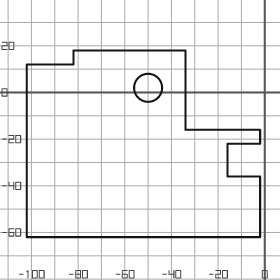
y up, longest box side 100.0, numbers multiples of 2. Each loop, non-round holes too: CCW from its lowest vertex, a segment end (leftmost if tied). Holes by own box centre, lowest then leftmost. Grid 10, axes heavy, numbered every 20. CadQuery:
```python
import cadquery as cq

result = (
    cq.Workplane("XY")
    .moveTo(-102.0, -62.0)
    .lineTo(-2.0, -62.0)
    .lineTo(-2.0, -36.0)
    .lineTo(-16.0, -36.0)
    .lineTo(-16.0, -22.0)
    .lineTo(-2.0, -22.0)
    .lineTo(-2.0, -16.0)
    .lineTo(-34.0, -16.0)
    .lineTo(-34.0, 18.0)
    .lineTo(-82.0, 18.0)
    .lineTo(-82.0, 12.0)
    .lineTo(-102.0, 12.0)
    .close()
    .moveTo(-50.0, 2.0)
    .circle(6.0)
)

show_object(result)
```